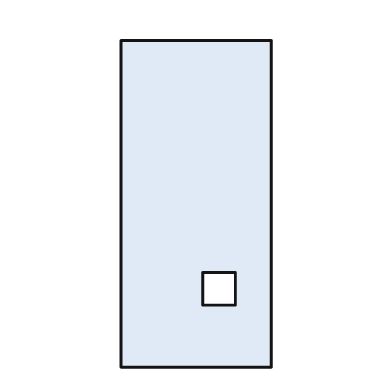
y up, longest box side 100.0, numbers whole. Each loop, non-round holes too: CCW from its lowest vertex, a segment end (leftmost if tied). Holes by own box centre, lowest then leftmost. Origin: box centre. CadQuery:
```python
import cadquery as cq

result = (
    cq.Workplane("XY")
    .moveTo(-23.0, -50.0)
    .lineTo(23.0, -50.0)
    .lineTo(23.0, 50.0)
    .lineTo(-23.0, 50.0)
    .close()
    .moveTo(2.0, -31.0)
    .lineTo(12.0, -31.0)
    .lineTo(12.0, -21.0)
    .lineTo(2.0, -21.0)
    .close()
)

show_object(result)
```